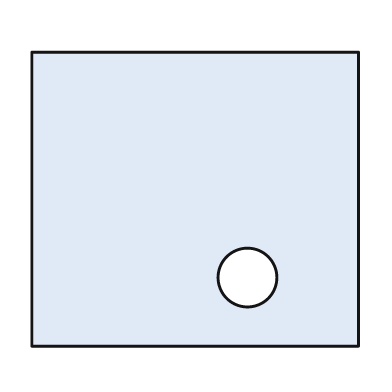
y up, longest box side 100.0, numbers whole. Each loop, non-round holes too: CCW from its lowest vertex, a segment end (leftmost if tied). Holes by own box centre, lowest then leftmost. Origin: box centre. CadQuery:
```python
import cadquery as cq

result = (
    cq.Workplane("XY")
    .moveTo(-50.0, -45.0)
    .lineTo(50.0, -45.0)
    .lineTo(50.0, 45.0)
    .lineTo(-50.0, 45.0)
    .close()
    .moveTo(16.0, -24.0)
    .circle(9.0)
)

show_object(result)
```